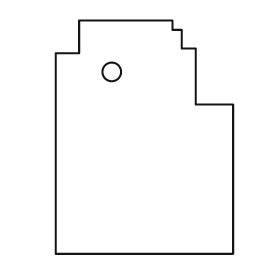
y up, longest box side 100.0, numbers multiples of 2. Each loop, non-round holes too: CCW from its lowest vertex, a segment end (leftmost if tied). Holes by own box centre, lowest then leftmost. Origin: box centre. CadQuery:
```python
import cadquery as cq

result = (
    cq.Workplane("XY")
    .moveTo(-38.0, -50.0)
    .lineTo(38.0, -50.0)
    .lineTo(38.0, 14.0)
    .lineTo(22.0, 14.0)
    .lineTo(22.0, 38.0)
    .lineTo(16.0, 38.0)
    .lineTo(16.0, 46.0)
    .lineTo(12.0, 46.0)
    .lineTo(12.0, 50.0)
    .lineTo(-28.0, 50.0)
    .lineTo(-28.0, 36.0)
    .lineTo(-38.0, 36.0)
    .close()
    .moveTo(-14.0, 28.0)
    .circle(4.0)
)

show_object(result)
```